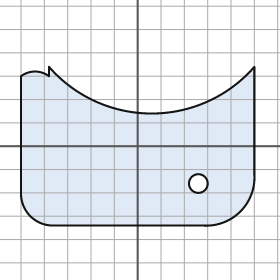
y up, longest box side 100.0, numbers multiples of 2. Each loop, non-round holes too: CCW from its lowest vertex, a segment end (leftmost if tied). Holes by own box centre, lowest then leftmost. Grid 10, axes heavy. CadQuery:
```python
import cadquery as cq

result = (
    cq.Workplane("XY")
    .moveTo(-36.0, -34.0)
    .lineTo(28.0, -34.0)
    .threePointArc((44.0, -28.0), (50.0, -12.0))
    .lineTo(50.0, 34.0)
    .threePointArc((6.0, 14.0), (-38.0, 34.0))
    .lineTo(-38.0, 30.0)
    .threePointArc((-44.0, 32.0), (-50.0, 30.0))
    .lineTo(-50.0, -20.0)
    .threePointArc((-46.0, -30.0), (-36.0, -34.0))
    .close()
    .moveTo(26.0, -16.0)
    .circle(4.0)
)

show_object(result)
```